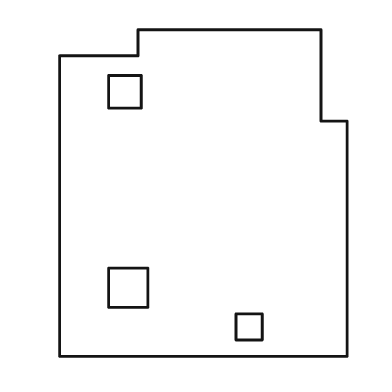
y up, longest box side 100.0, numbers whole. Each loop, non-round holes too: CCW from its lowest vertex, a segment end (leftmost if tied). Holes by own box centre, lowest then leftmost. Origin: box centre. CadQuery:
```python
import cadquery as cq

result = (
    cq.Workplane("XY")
    .moveTo(-44.0, -50.0)
    .lineTo(44.0, -50.0)
    .lineTo(44.0, 22.0)
    .lineTo(36.0, 22.0)
    .lineTo(36.0, 50.0)
    .lineTo(-20.0, 50.0)
    .lineTo(-20.0, 42.0)
    .lineTo(-44.0, 42.0)
    .close()
    .moveTo(10.0, -45.0)
    .lineTo(18.0, -45.0)
    .lineTo(18.0, -37.0)
    .lineTo(10.0, -37.0)
    .close()
    .moveTo(-29.0, -35.0)
    .lineTo(-17.0, -35.0)
    .lineTo(-17.0, -23.0)
    .lineTo(-29.0, -23.0)
    .close()
    .moveTo(-29.0, 26.0)
    .lineTo(-19.0, 26.0)
    .lineTo(-19.0, 36.0)
    .lineTo(-29.0, 36.0)
    .close()
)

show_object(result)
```